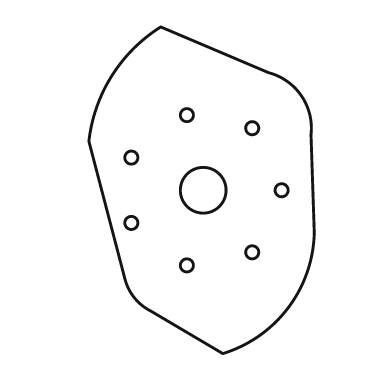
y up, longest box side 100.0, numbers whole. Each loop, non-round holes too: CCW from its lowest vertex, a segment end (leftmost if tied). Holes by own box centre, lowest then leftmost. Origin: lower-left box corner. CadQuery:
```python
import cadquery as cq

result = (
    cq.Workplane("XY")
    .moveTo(41.0, 0.0)
    .threePointArc((61.0, 14.0), (69.0, 37.0))
    .lineTo(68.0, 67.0)
    .threePointArc((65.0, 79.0), (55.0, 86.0))
    .lineTo(22.0, 100.0)
    .threePointArc((7.0, 85.0), (0.0, 65.0))
    .lineTo(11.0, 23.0)
    .threePointArc((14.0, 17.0), (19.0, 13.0))
    .close()
    .moveTo(30.0, 27.0)
    .circle(2.0)
    .moveTo(50.0, 31.0)
    .circle(2.0)
    .moveTo(13.0, 40.0)
    .circle(2.0)
    .moveTo(35.0, 50.0)
    .circle(7.0)
    .moveTo(59.0, 50.0)
    .circle(2.0)
    .moveTo(13.0, 60.0)
    .circle(2.0)
    .moveTo(50.0, 69.0)
    .circle(2.0)
    .moveTo(30.0, 73.0)
    .circle(2.0)
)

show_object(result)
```